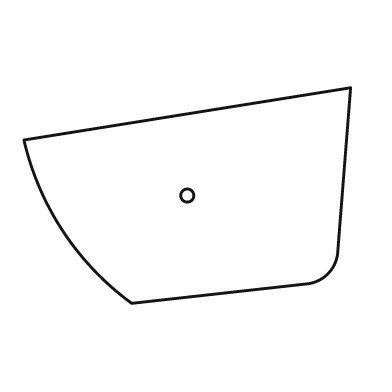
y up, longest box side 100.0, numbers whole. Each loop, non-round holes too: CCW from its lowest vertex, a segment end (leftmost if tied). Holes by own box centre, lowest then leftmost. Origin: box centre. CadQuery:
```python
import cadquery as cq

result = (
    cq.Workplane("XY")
    .moveTo(-17.0, -33.0)
    .lineTo(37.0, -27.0)
    .threePointArc((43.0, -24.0), (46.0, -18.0))
    .lineTo(50.0, 33.0)
    .lineTo(-50.0, 17.0)
    .threePointArc((-38.0, -11.0), (-17.0, -33.0))
    .close()
    .moveTo(0.0, 0.0)
    .circle(2.0)
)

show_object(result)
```